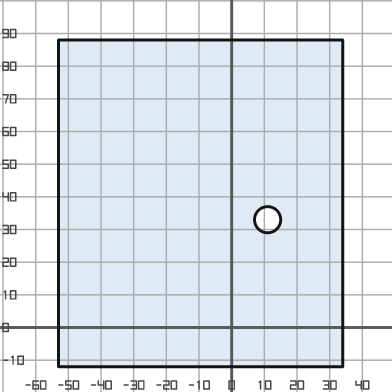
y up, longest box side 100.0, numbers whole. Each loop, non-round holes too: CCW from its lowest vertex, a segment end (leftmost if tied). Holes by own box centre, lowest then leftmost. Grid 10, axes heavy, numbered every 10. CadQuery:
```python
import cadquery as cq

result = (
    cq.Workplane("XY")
    .moveTo(-53.0, -12.0)
    .lineTo(34.0, -12.0)
    .lineTo(34.0, 88.0)
    .lineTo(-53.0, 88.0)
    .close()
    .moveTo(11.0, 33.0)
    .circle(4.0)
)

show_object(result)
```